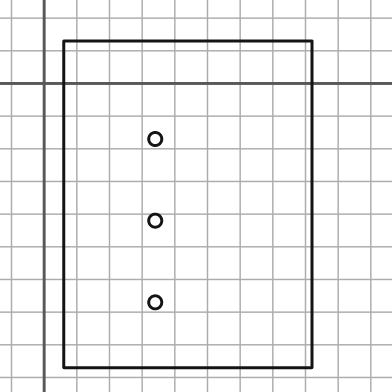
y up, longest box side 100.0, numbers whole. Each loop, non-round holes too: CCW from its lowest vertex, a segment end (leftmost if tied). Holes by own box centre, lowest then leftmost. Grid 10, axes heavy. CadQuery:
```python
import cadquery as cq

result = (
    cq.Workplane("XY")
    .moveTo(6.0, -87.0)
    .lineTo(82.0, -87.0)
    .lineTo(82.0, 13.0)
    .lineTo(6.0, 13.0)
    .close()
    .moveTo(34.0, -67.0)
    .circle(2.0)
    .moveTo(34.0, -42.0)
    .circle(2.0)
    .moveTo(34.0, -17.0)
    .circle(2.0)
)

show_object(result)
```